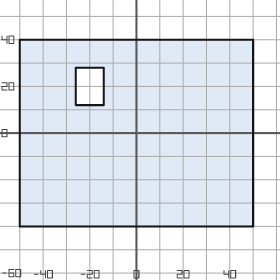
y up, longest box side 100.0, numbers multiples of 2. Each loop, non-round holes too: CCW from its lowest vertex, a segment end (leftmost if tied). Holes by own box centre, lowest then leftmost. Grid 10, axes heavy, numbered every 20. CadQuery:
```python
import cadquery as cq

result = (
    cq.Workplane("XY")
    .moveTo(-50.0, -40.0)
    .lineTo(50.0, -40.0)
    .lineTo(50.0, 40.0)
    .lineTo(-50.0, 40.0)
    .close()
    .moveTo(-26.0, 12.0)
    .lineTo(-14.0, 12.0)
    .lineTo(-14.0, 28.0)
    .lineTo(-26.0, 28.0)
    .close()
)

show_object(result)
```